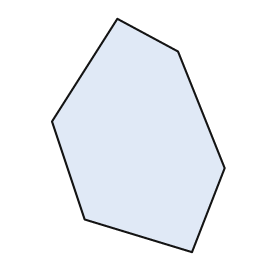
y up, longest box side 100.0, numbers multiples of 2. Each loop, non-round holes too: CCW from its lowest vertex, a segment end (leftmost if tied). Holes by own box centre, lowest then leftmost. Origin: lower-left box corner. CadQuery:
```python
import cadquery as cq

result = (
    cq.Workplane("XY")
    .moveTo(60.0, 0.0)
    .lineTo(74.0, 36.0)
    .lineTo(54.0, 86.0)
    .lineTo(28.0, 100.0)
    .lineTo(0.0, 56.0)
    .lineTo(14.0, 14.0)
    .close()
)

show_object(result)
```